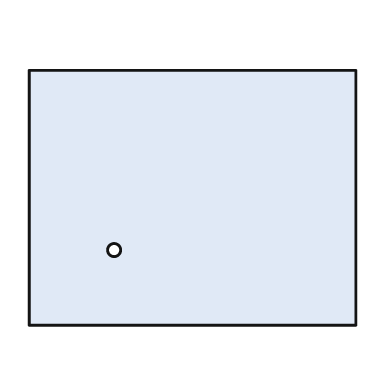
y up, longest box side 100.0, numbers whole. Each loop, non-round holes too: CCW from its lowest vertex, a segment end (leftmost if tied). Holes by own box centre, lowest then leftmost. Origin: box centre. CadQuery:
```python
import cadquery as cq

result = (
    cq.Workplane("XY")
    .moveTo(-50.0, -39.0)
    .lineTo(50.0, -39.0)
    .lineTo(50.0, 39.0)
    .lineTo(-50.0, 39.0)
    .close()
    .moveTo(-24.0, -16.0)
    .circle(2.0)
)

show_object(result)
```